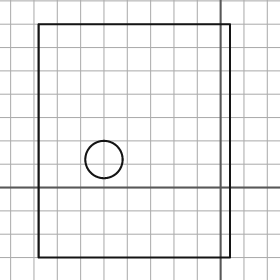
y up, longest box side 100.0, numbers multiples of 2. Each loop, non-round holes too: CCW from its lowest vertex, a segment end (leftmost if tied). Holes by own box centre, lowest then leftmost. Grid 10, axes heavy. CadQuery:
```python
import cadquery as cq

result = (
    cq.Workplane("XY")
    .moveTo(-78.0, -30.0)
    .lineTo(4.0, -30.0)
    .lineTo(4.0, 70.0)
    .lineTo(-78.0, 70.0)
    .close()
    .moveTo(-50.0, 12.0)
    .circle(8.0)
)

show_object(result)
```